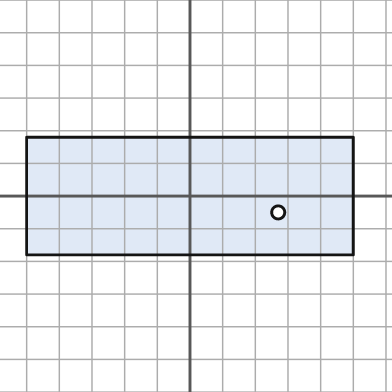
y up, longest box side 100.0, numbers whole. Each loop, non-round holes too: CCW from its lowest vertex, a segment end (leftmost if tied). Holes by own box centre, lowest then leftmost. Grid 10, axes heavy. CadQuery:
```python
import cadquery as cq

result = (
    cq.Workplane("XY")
    .moveTo(-50.0, -18.0)
    .lineTo(50.0, -18.0)
    .lineTo(50.0, 18.0)
    .lineTo(-50.0, 18.0)
    .close()
    .moveTo(27.0, -5.0)
    .circle(2.0)
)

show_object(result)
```